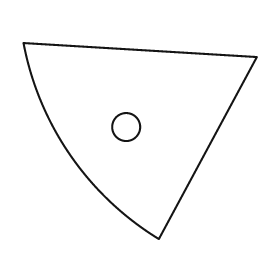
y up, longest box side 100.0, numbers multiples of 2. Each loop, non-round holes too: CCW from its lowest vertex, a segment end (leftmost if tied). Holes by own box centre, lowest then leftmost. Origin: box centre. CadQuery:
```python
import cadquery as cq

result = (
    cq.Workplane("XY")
    .moveTo(8.0, -42.0)
    .lineTo(50.0, 36.0)
    .lineTo(-50.0, 42.0)
    .threePointArc((-30.0, -6.0), (8.0, -42.0))
    .close()
    .moveTo(-6.0, 6.0)
    .circle(6.0)
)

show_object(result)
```